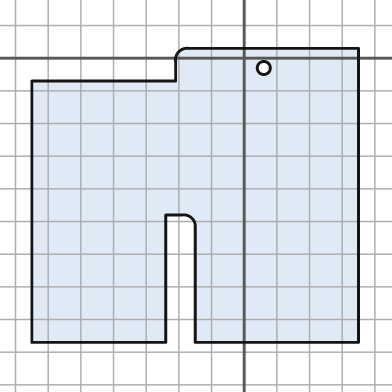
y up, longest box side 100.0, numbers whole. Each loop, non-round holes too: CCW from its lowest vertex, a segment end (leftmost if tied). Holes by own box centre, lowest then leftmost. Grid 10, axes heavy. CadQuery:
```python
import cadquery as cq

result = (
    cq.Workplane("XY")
    .moveTo(-65.0, -87.0)
    .lineTo(-24.0, -87.0)
    .lineTo(-24.0, -48.0)
    .lineTo(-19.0, -48.0)
    .threePointArc((-16.0, -49.0), (-15.0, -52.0))
    .lineTo(-15.0, -87.0)
    .lineTo(35.0, -87.0)
    .lineTo(35.0, 3.0)
    .lineTo(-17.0, 3.0)
    .threePointArc((-20.0, 2.0), (-21.0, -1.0))
    .lineTo(-21.0, -7.0)
    .lineTo(-65.0, -7.0)
    .close()
    .moveTo(6.0, -3.0)
    .circle(2.0)
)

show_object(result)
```